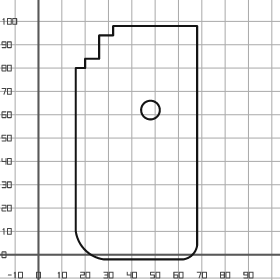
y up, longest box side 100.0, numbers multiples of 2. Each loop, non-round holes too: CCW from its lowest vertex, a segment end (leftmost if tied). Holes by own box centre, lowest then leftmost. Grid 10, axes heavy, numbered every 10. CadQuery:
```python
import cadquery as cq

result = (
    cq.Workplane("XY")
    .moveTo(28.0, -2.0)
    .lineTo(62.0, -2.0)
    .threePointArc((66.0, 0.0), (68.0, 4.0))
    .lineTo(68.0, 98.0)
    .lineTo(32.0, 98.0)
    .lineTo(32.0, 94.0)
    .lineTo(26.0, 94.0)
    .lineTo(26.0, 84.0)
    .lineTo(20.0, 84.0)
    .lineTo(20.0, 80.0)
    .lineTo(16.0, 80.0)
    .lineTo(16.0, 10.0)
    .threePointArc((20.0, 2.0), (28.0, -2.0))
    .close()
    .moveTo(48.0, 62.0)
    .circle(4.0)
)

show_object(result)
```